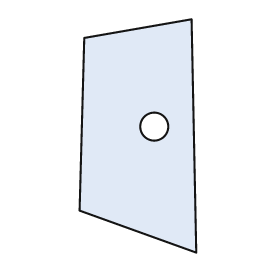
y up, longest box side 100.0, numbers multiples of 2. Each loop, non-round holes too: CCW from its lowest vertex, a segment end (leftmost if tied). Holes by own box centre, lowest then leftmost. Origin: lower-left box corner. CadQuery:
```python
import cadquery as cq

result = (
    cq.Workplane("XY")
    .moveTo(50.0, 0.0)
    .lineTo(48.0, 100.0)
    .lineTo(2.0, 92.0)
    .lineTo(0.0, 18.0)
    .close()
    .moveTo(32.0, 54.0)
    .circle(6.0)
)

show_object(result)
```